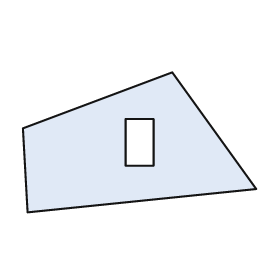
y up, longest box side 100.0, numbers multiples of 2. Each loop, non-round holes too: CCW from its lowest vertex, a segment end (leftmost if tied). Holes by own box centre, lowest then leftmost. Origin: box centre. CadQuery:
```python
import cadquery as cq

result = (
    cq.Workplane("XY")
    .moveTo(-48.0, -30.0)
    .lineTo(50.0, -20.0)
    .lineTo(14.0, 30.0)
    .lineTo(-50.0, 6.0)
    .close()
    .moveTo(-6.0, -10.0)
    .lineTo(6.0, -10.0)
    .lineTo(6.0, 10.0)
    .lineTo(-6.0, 10.0)
    .close()
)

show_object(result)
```